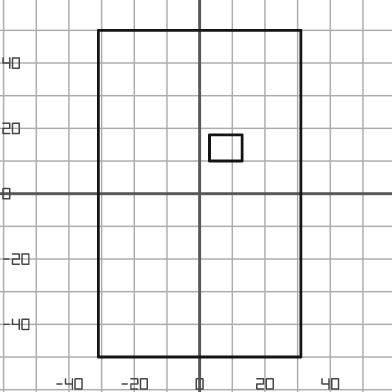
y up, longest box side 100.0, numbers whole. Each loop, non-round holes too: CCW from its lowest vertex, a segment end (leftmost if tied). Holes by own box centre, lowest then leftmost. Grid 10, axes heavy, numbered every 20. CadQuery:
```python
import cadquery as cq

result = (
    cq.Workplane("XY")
    .moveTo(-31.0, -50.0)
    .lineTo(31.0, -50.0)
    .lineTo(31.0, 50.0)
    .lineTo(-31.0, 50.0)
    .close()
    .moveTo(3.0, 10.0)
    .lineTo(13.0, 10.0)
    .lineTo(13.0, 18.0)
    .lineTo(3.0, 18.0)
    .close()
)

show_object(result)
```